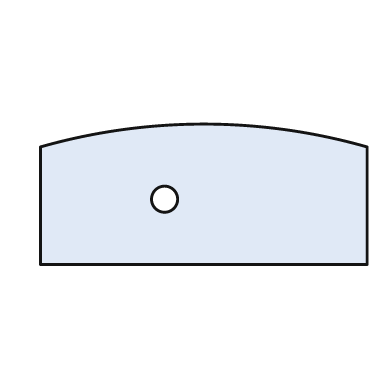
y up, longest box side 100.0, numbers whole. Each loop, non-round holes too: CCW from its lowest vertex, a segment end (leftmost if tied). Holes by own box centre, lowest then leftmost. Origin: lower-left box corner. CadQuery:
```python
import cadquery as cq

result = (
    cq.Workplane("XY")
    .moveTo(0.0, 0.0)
    .lineTo(100.0, 0.0)
    .lineTo(100.0, 36.0)
    .threePointArc((50.0, 43.0), (0.0, 36.0))
    .close()
    .moveTo(38.0, 20.0)
    .circle(4.0)
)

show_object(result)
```